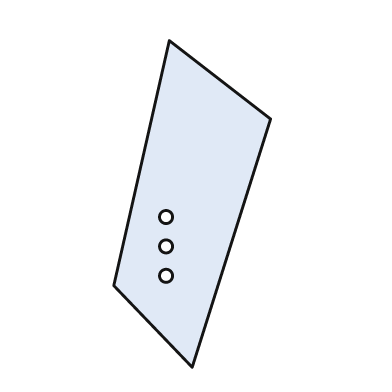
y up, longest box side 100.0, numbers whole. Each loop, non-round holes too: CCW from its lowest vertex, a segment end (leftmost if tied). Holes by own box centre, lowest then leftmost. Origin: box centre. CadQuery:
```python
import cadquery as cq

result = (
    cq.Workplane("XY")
    .moveTo(0.0, -50.0)
    .lineTo(24.0, 26.0)
    .lineTo(-7.0, 50.0)
    .lineTo(-24.0, -25.0)
    .close()
    .moveTo(-8.0, -22.0)
    .circle(2.0)
    .moveTo(-8.0, -13.0)
    .circle(2.0)
    .moveTo(-8.0, -4.0)
    .circle(2.0)
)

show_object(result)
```